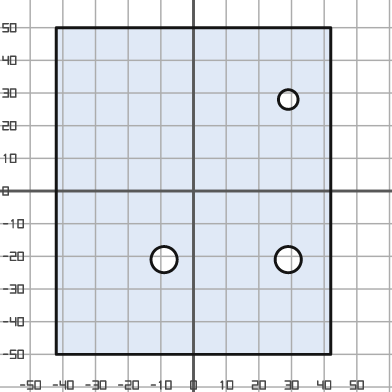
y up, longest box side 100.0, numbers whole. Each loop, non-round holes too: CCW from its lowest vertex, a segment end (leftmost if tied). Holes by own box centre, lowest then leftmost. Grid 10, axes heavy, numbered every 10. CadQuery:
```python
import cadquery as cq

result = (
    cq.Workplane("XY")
    .moveTo(-42.0, -50.0)
    .lineTo(42.0, -50.0)
    .lineTo(42.0, 50.0)
    .lineTo(-42.0, 50.0)
    .close()
    .moveTo(-9.0, -21.0)
    .circle(4.0)
    .moveTo(29.0, -21.0)
    .circle(4.0)
    .moveTo(29.0, 28.0)
    .circle(3.0)
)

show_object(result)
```